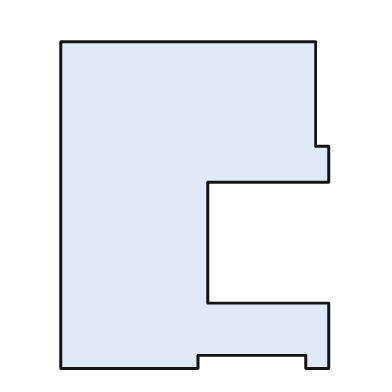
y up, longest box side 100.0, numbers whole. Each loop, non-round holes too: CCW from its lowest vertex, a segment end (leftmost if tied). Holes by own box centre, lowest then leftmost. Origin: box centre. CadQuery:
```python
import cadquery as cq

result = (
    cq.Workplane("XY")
    .moveTo(-41.0, -50.0)
    .lineTo(1.0, -50.0)
    .lineTo(1.0, -46.0)
    .lineTo(34.0, -46.0)
    .lineTo(34.0, -50.0)
    .lineTo(41.0, -50.0)
    .lineTo(41.0, -30.0)
    .lineTo(4.0, -30.0)
    .lineTo(4.0, 7.0)
    .lineTo(41.0, 7.0)
    .lineTo(41.0, 18.0)
    .lineTo(37.0, 18.0)
    .lineTo(37.0, 50.0)
    .lineTo(-41.0, 50.0)
    .close()
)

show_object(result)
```